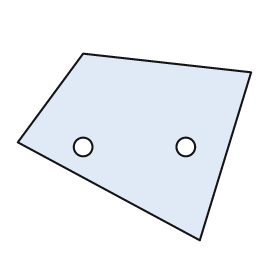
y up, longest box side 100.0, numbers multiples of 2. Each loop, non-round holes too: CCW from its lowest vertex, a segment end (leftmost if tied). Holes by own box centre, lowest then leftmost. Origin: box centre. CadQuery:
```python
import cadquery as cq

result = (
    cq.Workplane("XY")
    .moveTo(28.0, -40.0)
    .lineTo(50.0, 32.0)
    .lineTo(-22.0, 40.0)
    .lineTo(-50.0, 2.0)
    .close()
    .moveTo(-22.0, 0.0)
    .circle(4.0)
    .moveTo(22.0, 0.0)
    .circle(4.0)
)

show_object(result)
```